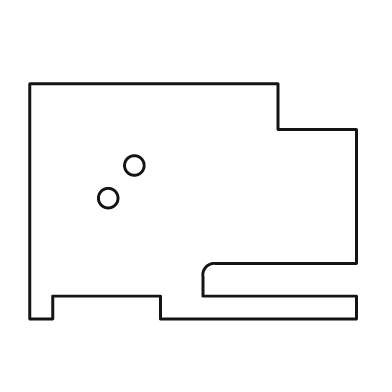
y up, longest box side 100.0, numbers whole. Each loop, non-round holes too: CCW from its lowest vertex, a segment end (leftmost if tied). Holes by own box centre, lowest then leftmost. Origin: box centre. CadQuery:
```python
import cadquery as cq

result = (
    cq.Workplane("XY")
    .moveTo(-50.0, -36.0)
    .lineTo(-43.0, -36.0)
    .lineTo(-43.0, -29.0)
    .lineTo(-10.0, -29.0)
    .lineTo(-10.0, -36.0)
    .lineTo(50.0, -36.0)
    .lineTo(50.0, -29.0)
    .lineTo(3.0, -29.0)
    .lineTo(3.0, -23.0)
    .threePointArc((4.0, -20.0), (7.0, -19.0))
    .lineTo(50.0, -19.0)
    .lineTo(50.0, 22.0)
    .lineTo(26.0, 22.0)
    .lineTo(26.0, 36.0)
    .lineTo(-50.0, 36.0)
    .close()
    .moveTo(-26.0, 1.0)
    .circle(3.0)
    .moveTo(-18.0, 11.0)
    .circle(3.0)
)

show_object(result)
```